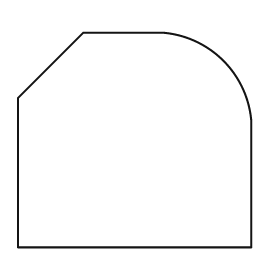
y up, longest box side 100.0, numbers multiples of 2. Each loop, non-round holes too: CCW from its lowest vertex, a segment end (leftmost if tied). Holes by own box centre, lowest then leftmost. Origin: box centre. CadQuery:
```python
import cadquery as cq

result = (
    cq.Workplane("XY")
    .moveTo(-50.0, -46.0)
    .lineTo(50.0, -46.0)
    .lineTo(50.0, 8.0)
    .threePointArc((38.0, 34.0), (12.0, 46.0))
    .lineTo(-22.0, 46.0)
    .lineTo(-50.0, 18.0)
    .close()
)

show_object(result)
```